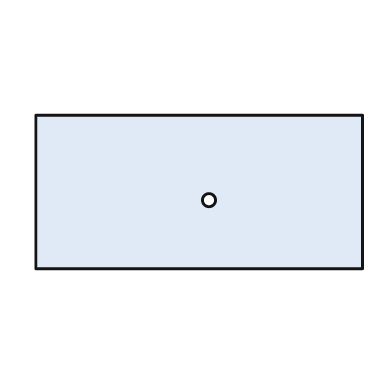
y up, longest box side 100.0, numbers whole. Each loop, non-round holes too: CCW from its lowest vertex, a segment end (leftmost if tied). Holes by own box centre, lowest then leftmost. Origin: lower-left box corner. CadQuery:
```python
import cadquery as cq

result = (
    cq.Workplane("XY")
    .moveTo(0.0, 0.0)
    .lineTo(100.0, 0.0)
    .lineTo(100.0, 47.0)
    .lineTo(0.0, 47.0)
    .close()
    .moveTo(53.0, 21.0)
    .circle(2.0)
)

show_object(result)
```